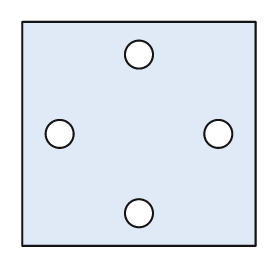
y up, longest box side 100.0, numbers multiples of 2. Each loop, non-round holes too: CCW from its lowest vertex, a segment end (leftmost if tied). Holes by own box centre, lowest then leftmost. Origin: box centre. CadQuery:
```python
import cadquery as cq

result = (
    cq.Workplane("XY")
    .moveTo(-50.0, -48.0)
    .lineTo(50.0, -48.0)
    .lineTo(50.0, 48.0)
    .lineTo(-50.0, 48.0)
    .close()
    .moveTo(0.0, -34.0)
    .circle(6.0)
    .moveTo(-34.0, 0.0)
    .circle(6.0)
    .moveTo(34.0, 0.0)
    .circle(6.0)
    .moveTo(0.0, 34.0)
    .circle(6.0)
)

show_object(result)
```